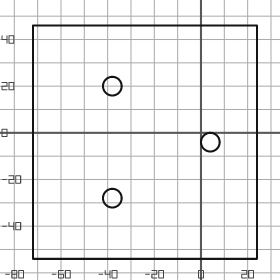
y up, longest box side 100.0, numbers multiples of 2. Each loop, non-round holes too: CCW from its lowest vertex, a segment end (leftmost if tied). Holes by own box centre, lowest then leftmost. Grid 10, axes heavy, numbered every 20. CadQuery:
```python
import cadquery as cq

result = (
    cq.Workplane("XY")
    .moveTo(-72.0, -54.0)
    .lineTo(24.0, -54.0)
    .lineTo(24.0, 46.0)
    .lineTo(-72.0, 46.0)
    .close()
    .moveTo(-38.0, -28.0)
    .circle(4.0)
    .moveTo(4.0, -4.0)
    .circle(4.0)
    .moveTo(-38.0, 20.0)
    .circle(4.0)
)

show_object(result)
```